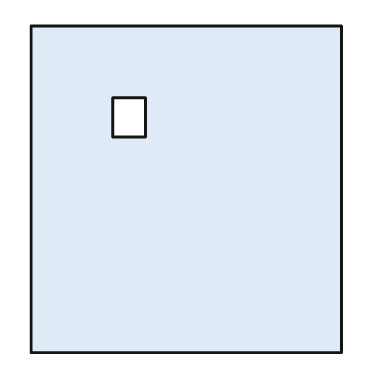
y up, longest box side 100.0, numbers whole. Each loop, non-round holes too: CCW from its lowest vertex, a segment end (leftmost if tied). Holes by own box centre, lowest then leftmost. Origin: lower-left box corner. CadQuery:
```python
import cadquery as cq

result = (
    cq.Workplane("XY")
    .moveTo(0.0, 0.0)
    .lineTo(95.0, 0.0)
    .lineTo(95.0, 100.0)
    .lineTo(0.0, 100.0)
    .close()
    .moveTo(25.0, 66.0)
    .lineTo(35.0, 66.0)
    .lineTo(35.0, 78.0)
    .lineTo(25.0, 78.0)
    .close()
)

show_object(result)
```